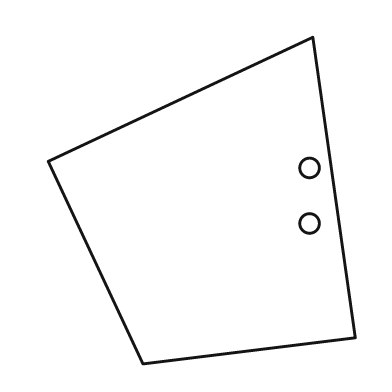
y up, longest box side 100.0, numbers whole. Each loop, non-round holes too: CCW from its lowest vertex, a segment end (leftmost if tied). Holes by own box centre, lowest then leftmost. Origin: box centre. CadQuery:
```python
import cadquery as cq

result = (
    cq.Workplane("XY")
    .moveTo(-18.0, -50.0)
    .lineTo(47.0, -42.0)
    .lineTo(34.0, 50.0)
    .lineTo(-47.0, 12.0)
    .close()
    .moveTo(33.0, -7.0)
    .circle(3.0)
    .moveTo(33.0, 10.0)
    .circle(3.0)
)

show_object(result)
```